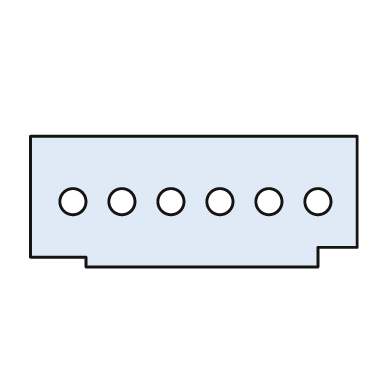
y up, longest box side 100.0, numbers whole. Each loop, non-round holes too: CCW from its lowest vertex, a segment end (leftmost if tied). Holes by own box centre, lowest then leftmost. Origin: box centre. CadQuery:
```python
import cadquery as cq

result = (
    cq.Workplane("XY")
    .moveTo(-33.0, -20.0)
    .lineTo(38.0, -20.0)
    .lineTo(38.0, -14.0)
    .lineTo(50.0, -14.0)
    .lineTo(50.0, 20.0)
    .lineTo(-50.0, 20.0)
    .lineTo(-50.0, -17.0)
    .lineTo(-33.0, -17.0)
    .close()
    .moveTo(-37.0, 0.0)
    .circle(4.0)
    .moveTo(-22.0, 0.0)
    .circle(4.0)
    .moveTo(-7.0, 0.0)
    .circle(4.0)
    .moveTo(8.0, 0.0)
    .circle(4.0)
    .moveTo(23.0, 0.0)
    .circle(4.0)
    .moveTo(38.0, 0.0)
    .circle(4.0)
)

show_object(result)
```